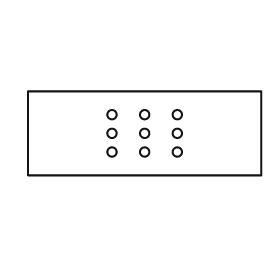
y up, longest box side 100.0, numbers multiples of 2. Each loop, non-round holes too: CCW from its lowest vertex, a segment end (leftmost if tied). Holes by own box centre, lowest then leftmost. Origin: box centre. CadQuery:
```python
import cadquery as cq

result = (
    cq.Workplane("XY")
    .moveTo(-50.0, -18.0)
    .lineTo(50.0, -18.0)
    .lineTo(50.0, 18.0)
    .lineTo(-50.0, 18.0)
    .close()
    .moveTo(-14.0, -8.0)
    .circle(2.0)
    .moveTo(0.0, -8.0)
    .circle(2.0)
    .moveTo(14.0, -8.0)
    .circle(2.0)
    .moveTo(-14.0, 0.0)
    .circle(2.0)
    .moveTo(0.0, 0.0)
    .circle(2.0)
    .moveTo(14.0, 0.0)
    .circle(2.0)
    .moveTo(-14.0, 8.0)
    .circle(2.0)
    .moveTo(0.0, 8.0)
    .circle(2.0)
    .moveTo(14.0, 8.0)
    .circle(2.0)
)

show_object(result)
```